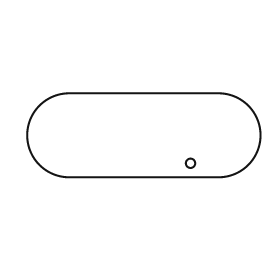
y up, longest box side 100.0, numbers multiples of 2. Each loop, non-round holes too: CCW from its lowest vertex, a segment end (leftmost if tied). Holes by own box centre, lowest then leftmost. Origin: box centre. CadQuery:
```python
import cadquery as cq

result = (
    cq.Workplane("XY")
    .moveTo(-32.0, -18.0)
    .lineTo(32.0, -18.0)
    .threePointArc((50.0, 0.0), (32.0, 18.0))
    .lineTo(-32.0, 18.0)
    .threePointArc((-50.0, 0.0), (-32.0, -18.0))
    .close()
    .moveTo(20.0, -12.0)
    .circle(2.0)
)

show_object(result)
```